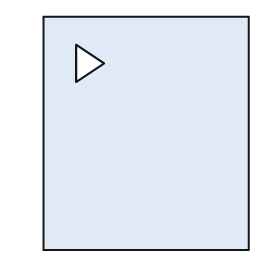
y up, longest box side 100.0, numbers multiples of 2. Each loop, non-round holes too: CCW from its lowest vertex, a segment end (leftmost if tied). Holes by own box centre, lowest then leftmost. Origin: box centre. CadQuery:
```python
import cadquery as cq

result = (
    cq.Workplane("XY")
    .moveTo(-44.0, -50.0)
    .lineTo(44.0, -50.0)
    .lineTo(44.0, 50.0)
    .lineTo(-44.0, 50.0)
    .close()
    .moveTo(-30.0, 22.0)
    .lineTo(-18.0, 30.0)
    .lineTo(-30.0, 38.0)
    .close()
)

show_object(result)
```